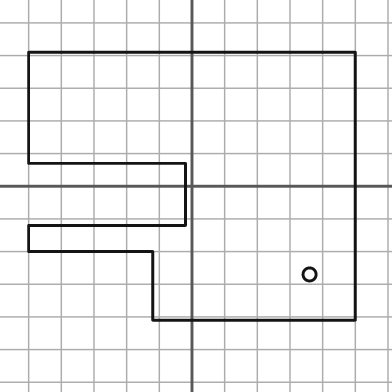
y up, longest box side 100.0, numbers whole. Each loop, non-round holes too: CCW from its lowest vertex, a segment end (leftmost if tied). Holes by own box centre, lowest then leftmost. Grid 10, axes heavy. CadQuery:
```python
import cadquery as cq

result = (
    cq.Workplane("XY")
    .moveTo(-12.0, -41.0)
    .lineTo(50.0, -41.0)
    .lineTo(50.0, 41.0)
    .lineTo(-50.0, 41.0)
    .lineTo(-50.0, 7.0)
    .lineTo(-2.0, 7.0)
    .lineTo(-2.0, -12.0)
    .lineTo(-50.0, -12.0)
    .lineTo(-50.0, -20.0)
    .lineTo(-12.0, -20.0)
    .close()
    .moveTo(36.0, -27.0)
    .circle(2.0)
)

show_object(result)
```